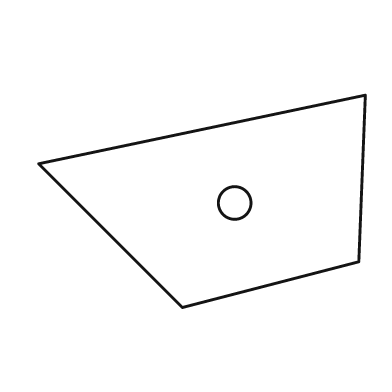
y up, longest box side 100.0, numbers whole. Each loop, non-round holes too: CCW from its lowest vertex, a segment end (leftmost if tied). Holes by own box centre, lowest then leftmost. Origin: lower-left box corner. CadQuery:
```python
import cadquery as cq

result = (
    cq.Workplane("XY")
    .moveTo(44.0, 0.0)
    .lineTo(98.0, 14.0)
    .lineTo(100.0, 65.0)
    .lineTo(0.0, 44.0)
    .close()
    .moveTo(60.0, 32.0)
    .circle(5.0)
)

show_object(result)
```